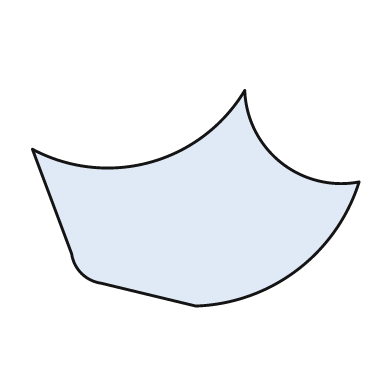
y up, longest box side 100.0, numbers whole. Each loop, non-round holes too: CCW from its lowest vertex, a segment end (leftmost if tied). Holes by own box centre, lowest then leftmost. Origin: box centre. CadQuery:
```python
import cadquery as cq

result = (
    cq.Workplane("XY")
    .moveTo(0.0, -33.0)
    .threePointArc((31.0, -22.0), (50.0, 5.0))
    .threePointArc((26.0, 11.0), (15.0, 33.0))
    .threePointArc((-14.0, 11.0), (-50.0, 15.0))
    .lineTo(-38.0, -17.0)
    .threePointArc((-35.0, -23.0), (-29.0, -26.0))
    .close()
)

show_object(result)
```